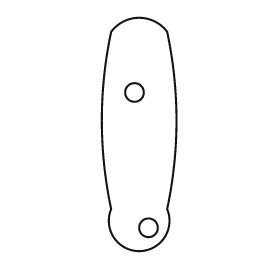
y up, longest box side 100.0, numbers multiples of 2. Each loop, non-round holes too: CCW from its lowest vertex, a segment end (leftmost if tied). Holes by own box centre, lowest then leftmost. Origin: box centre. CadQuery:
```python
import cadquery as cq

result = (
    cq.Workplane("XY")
    .moveTo(-12.0, -32.0)
    .threePointArc((0.0, -50.0), (12.0, -32.0))
    .threePointArc((16.0, 6.0), (12.0, 44.0))
    .threePointArc((0.0, 50.0), (-12.0, 44.0))
    .threePointArc((-16.0, 6.0), (-12.0, -32.0))
    .close()
    .moveTo(4.0, -40.0)
    .circle(4.0)
    .moveTo(-2.0, 18.0)
    .circle(4.0)
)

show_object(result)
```